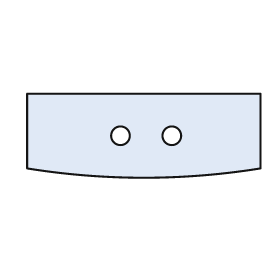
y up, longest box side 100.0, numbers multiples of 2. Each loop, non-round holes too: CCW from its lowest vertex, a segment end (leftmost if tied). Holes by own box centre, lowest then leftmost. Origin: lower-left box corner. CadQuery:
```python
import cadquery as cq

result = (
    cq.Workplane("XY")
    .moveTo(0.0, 4.0)
    .threePointArc((50.0, 0.0), (100.0, 4.0))
    .lineTo(100.0, 36.0)
    .lineTo(0.0, 36.0)
    .close()
    .moveTo(40.0, 18.0)
    .circle(4.0)
    .moveTo(62.0, 18.0)
    .circle(4.0)
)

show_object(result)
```